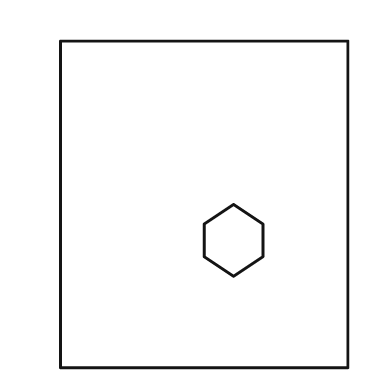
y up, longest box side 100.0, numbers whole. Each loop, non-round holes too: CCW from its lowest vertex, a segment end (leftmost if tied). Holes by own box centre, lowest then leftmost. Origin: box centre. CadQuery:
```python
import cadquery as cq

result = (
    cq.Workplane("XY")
    .moveTo(-44.0, -50.0)
    .lineTo(44.0, -50.0)
    .lineTo(44.0, 50.0)
    .lineTo(-44.0, 50.0)
    .close()
    .moveTo(9.0, -22.0)
    .lineTo(18.0, -16.0)
    .lineTo(18.0, -6.0)
    .lineTo(9.0, 0.0)
    .lineTo(0.0, -6.0)
    .lineTo(0.0, -16.0)
    .close()
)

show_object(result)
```